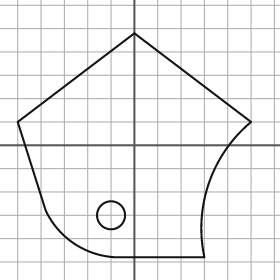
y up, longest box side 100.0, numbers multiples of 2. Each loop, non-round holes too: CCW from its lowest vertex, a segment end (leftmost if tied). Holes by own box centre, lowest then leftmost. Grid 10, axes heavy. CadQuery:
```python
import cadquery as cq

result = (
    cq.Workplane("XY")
    .moveTo(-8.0, -48.0)
    .lineTo(30.0, -48.0)
    .threePointArc((32.0, -16.0), (50.0, 10.0))
    .lineTo(0.0, 48.0)
    .lineTo(-50.0, 10.0)
    .lineTo(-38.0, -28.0)
    .threePointArc((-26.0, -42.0), (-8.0, -48.0))
    .close()
    .moveTo(-10.0, -30.0)
    .circle(6.0)
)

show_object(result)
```